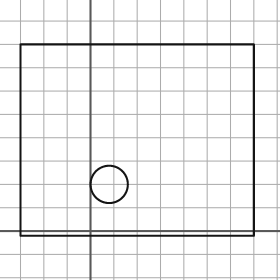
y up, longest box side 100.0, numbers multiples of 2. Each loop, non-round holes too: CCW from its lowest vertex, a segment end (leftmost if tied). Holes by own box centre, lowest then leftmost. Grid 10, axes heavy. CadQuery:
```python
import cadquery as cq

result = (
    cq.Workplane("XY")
    .moveTo(-30.0, -2.0)
    .lineTo(70.0, -2.0)
    .lineTo(70.0, 80.0)
    .lineTo(-30.0, 80.0)
    .close()
    .moveTo(8.0, 20.0)
    .circle(8.0)
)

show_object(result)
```